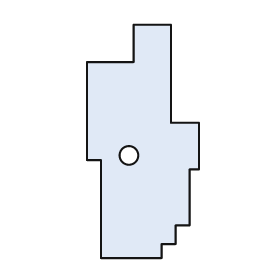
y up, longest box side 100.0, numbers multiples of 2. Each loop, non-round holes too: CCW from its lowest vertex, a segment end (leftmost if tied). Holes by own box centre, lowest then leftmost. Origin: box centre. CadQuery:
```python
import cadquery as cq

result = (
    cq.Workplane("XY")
    .moveTo(-18.0, -50.0)
    .lineTo(8.0, -50.0)
    .lineTo(8.0, -44.0)
    .lineTo(14.0, -44.0)
    .lineTo(14.0, -36.0)
    .lineTo(20.0, -36.0)
    .lineTo(20.0, -12.0)
    .lineTo(24.0, -12.0)
    .lineTo(24.0, 8.0)
    .lineTo(12.0, 8.0)
    .lineTo(12.0, 50.0)
    .lineTo(-4.0, 50.0)
    .lineTo(-4.0, 34.0)
    .lineTo(-24.0, 34.0)
    .lineTo(-24.0, -8.0)
    .lineTo(-18.0, -8.0)
    .close()
    .moveTo(-6.0, -6.0)
    .circle(4.0)
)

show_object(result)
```